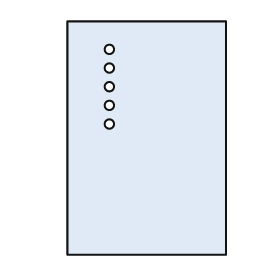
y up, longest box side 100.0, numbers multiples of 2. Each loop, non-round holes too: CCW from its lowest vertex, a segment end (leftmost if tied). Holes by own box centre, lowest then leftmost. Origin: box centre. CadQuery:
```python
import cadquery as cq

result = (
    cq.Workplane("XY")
    .moveTo(-34.0, -50.0)
    .lineTo(34.0, -50.0)
    .lineTo(34.0, 50.0)
    .lineTo(-34.0, 50.0)
    .close()
    .moveTo(-16.0, 6.0)
    .circle(2.0)
    .moveTo(-16.0, 14.0)
    .circle(2.0)
    .moveTo(-16.0, 22.0)
    .circle(2.0)
    .moveTo(-16.0, 30.0)
    .circle(2.0)
    .moveTo(-16.0, 38.0)
    .circle(2.0)
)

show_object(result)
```